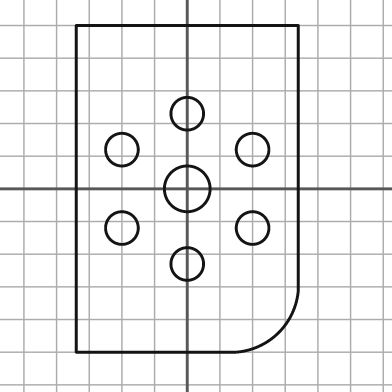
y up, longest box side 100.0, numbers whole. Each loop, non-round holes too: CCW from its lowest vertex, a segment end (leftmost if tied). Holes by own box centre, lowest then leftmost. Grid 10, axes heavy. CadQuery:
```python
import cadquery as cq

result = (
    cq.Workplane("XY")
    .moveTo(-34.0, -50.0)
    .lineTo(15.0, -50.0)
    .threePointArc((28.0, -44.0), (34.0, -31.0))
    .lineTo(34.0, 50.0)
    .lineTo(-34.0, 50.0)
    .close()
    .moveTo(0.0, -23.0)
    .circle(5.0)
    .moveTo(-20.0, -12.0)
    .circle(5.0)
    .moveTo(20.0, -12.0)
    .circle(5.0)
    .moveTo(0.0, 0.0)
    .circle(7.0)
    .moveTo(-20.0, 12.0)
    .circle(5.0)
    .moveTo(20.0, 12.0)
    .circle(5.0)
    .moveTo(0.0, 23.0)
    .circle(5.0)
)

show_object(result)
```